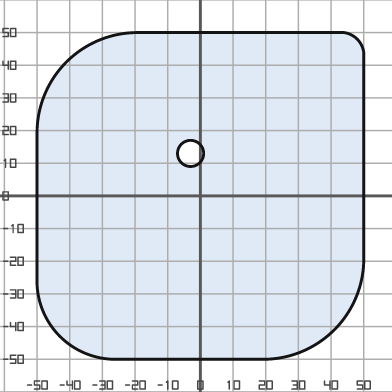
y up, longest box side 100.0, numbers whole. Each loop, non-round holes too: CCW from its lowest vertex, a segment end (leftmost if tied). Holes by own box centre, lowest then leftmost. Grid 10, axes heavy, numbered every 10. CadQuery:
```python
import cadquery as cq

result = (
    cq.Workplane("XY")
    .moveTo(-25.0, -50.0)
    .lineTo(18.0, -50.0)
    .threePointArc((41.0, -41.0), (50.0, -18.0))
    .lineTo(50.0, 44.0)
    .threePointArc((48.0, 48.0), (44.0, 50.0))
    .lineTo(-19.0, 50.0)
    .threePointArc((-41.0, 41.0), (-50.0, 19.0))
    .lineTo(-50.0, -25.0)
    .threePointArc((-43.0, -43.0), (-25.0, -50.0))
    .close()
    .moveTo(-3.0, 13.0)
    .circle(4.0)
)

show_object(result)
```